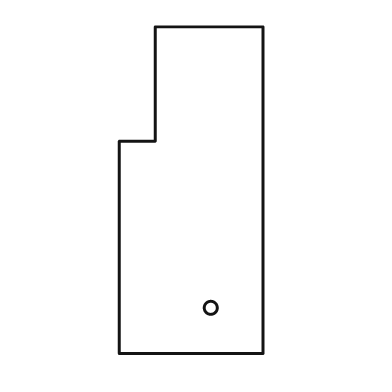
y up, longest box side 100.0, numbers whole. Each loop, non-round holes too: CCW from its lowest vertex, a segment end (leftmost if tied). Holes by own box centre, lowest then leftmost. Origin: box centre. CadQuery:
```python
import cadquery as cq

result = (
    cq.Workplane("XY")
    .moveTo(-22.0, -50.0)
    .lineTo(22.0, -50.0)
    .lineTo(22.0, 50.0)
    .lineTo(-11.0, 50.0)
    .lineTo(-11.0, 15.0)
    .lineTo(-22.0, 15.0)
    .close()
    .moveTo(6.0, -36.0)
    .circle(2.0)
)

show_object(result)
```